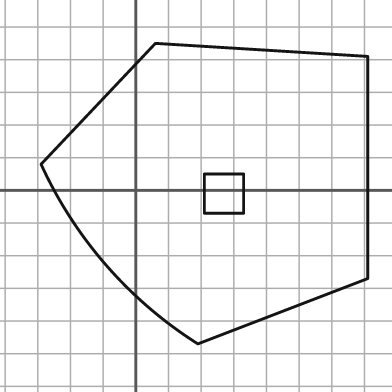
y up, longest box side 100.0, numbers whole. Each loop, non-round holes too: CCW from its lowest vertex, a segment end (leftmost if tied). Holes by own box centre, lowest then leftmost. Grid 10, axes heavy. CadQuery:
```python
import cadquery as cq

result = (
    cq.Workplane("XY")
    .moveTo(19.0, -47.0)
    .lineTo(71.0, -27.0)
    .lineTo(71.0, 41.0)
    .lineTo(6.0, 45.0)
    .lineTo(-29.0, 8.0)
    .threePointArc((-9.0, -23.0), (19.0, -47.0))
    .close()
    .moveTo(21.0, -7.0)
    .lineTo(33.0, -7.0)
    .lineTo(33.0, 5.0)
    .lineTo(21.0, 5.0)
    .close()
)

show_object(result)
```